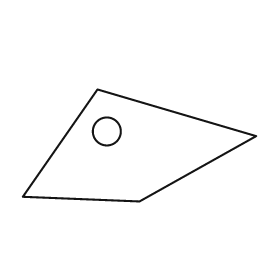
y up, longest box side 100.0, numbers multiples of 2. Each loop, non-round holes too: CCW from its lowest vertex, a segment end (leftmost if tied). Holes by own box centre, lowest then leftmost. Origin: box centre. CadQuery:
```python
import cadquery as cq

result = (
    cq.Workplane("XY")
    .moveTo(0.0, -24.0)
    .lineTo(50.0, 4.0)
    .lineTo(-18.0, 24.0)
    .lineTo(-50.0, -22.0)
    .close()
    .moveTo(-14.0, 6.0)
    .circle(6.0)
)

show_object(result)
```